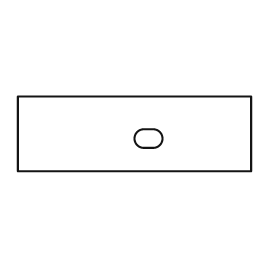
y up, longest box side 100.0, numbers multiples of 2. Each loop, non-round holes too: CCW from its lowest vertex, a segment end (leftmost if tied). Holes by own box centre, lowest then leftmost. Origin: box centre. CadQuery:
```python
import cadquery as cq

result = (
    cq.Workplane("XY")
    .moveTo(-50.0, -16.0)
    .lineTo(50.0, -16.0)
    .lineTo(50.0, 16.0)
    .lineTo(-50.0, 16.0)
    .close()
    .moveTo(4.0, -6.0)
    .lineTo(8.0, -6.0)
    .threePointArc((12.0, -2.0), (8.0, 2.0))
    .lineTo(4.0, 2.0)
    .threePointArc((0.0, -2.0), (4.0, -6.0))
    .close()
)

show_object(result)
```